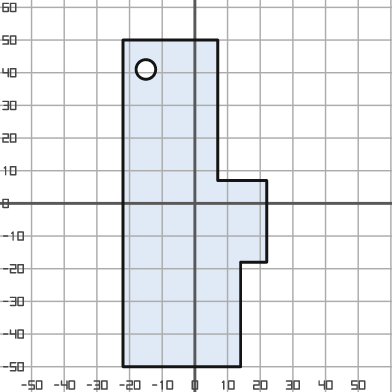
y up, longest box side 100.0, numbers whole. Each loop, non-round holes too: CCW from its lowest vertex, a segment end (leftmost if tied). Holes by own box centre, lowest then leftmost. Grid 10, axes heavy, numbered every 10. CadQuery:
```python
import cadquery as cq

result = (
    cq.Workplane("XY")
    .moveTo(-22.0, -50.0)
    .lineTo(14.0, -50.0)
    .lineTo(14.0, -18.0)
    .lineTo(22.0, -18.0)
    .lineTo(22.0, 7.0)
    .lineTo(7.0, 7.0)
    .lineTo(7.0, 50.0)
    .lineTo(-22.0, 50.0)
    .close()
    .moveTo(-15.0, 41.0)
    .circle(3.0)
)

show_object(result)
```